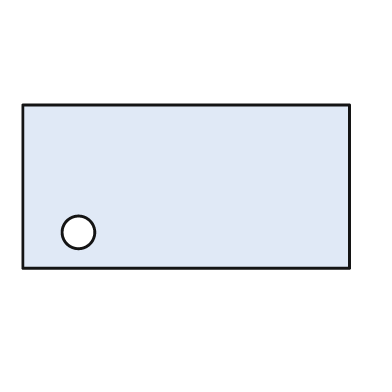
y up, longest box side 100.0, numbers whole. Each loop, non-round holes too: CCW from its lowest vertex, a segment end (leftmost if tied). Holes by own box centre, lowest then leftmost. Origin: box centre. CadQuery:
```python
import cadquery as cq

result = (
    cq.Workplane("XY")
    .moveTo(-50.0, -25.0)
    .lineTo(50.0, -25.0)
    .lineTo(50.0, 25.0)
    .lineTo(-50.0, 25.0)
    .close()
    .moveTo(-33.0, -14.0)
    .circle(5.0)
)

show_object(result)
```